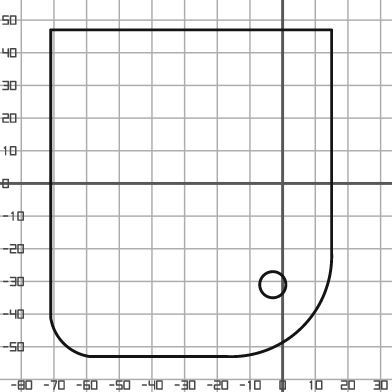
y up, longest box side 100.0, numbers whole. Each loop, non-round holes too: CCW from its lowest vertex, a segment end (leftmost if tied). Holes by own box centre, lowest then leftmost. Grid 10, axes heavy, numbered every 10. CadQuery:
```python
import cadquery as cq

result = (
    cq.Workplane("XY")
    .moveTo(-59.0, -53.0)
    .lineTo(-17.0, -53.0)
    .threePointArc((6.0, -44.0), (15.0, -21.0))
    .lineTo(15.0, 47.0)
    .lineTo(-71.0, 47.0)
    .lineTo(-71.0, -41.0)
    .threePointArc((-67.0, -49.0), (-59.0, -53.0))
    .close()
    .moveTo(-3.0, -31.0)
    .circle(4.0)
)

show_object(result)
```